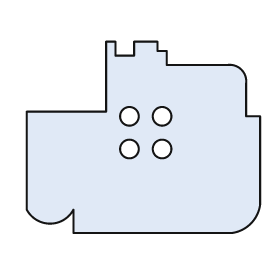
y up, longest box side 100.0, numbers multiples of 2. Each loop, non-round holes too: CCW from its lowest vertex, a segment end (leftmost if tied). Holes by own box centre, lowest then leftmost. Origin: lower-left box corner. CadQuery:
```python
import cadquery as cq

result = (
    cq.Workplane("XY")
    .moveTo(20.0, 0.0)
    .lineTo(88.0, 0.0)
    .threePointArc((96.0, 4.0), (100.0, 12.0))
    .lineTo(100.0, 50.0)
    .lineTo(94.0, 50.0)
    .lineTo(94.0, 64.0)
    .threePointArc((92.0, 70.0), (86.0, 72.0))
    .lineTo(60.0, 72.0)
    .lineTo(60.0, 78.0)
    .lineTo(56.0, 78.0)
    .lineTo(56.0, 82.0)
    .lineTo(46.0, 82.0)
    .lineTo(46.0, 76.0)
    .lineTo(38.0, 76.0)
    .lineTo(38.0, 82.0)
    .lineTo(34.0, 82.0)
    .lineTo(34.0, 52.0)
    .lineTo(0.0, 52.0)
    .lineTo(0.0, 10.0)
    .threePointArc((10.0, 4.0), (20.0, 10.0))
    .close()
    .moveTo(44.0, 36.0)
    .circle(4.0)
    .moveTo(58.0, 36.0)
    .circle(4.0)
    .moveTo(44.0, 50.0)
    .circle(4.0)
    .moveTo(58.0, 50.0)
    .circle(4.0)
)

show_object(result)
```